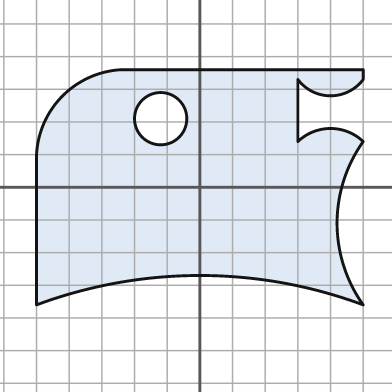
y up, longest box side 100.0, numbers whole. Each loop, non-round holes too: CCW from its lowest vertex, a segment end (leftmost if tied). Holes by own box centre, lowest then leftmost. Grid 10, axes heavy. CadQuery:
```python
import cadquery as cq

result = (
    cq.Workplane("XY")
    .moveTo(-50.0, -36.0)
    .threePointArc((0.0, -27.0), (50.0, -36.0))
    .threePointArc((42.0, -11.0), (50.0, 14.0))
    .threePointArc((40.0, 18.0), (30.0, 14.0))
    .lineTo(30.0, 33.0)
    .threePointArc((40.0, 28.0), (50.0, 33.0))
    .lineTo(50.0, 36.0)
    .lineTo(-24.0, 36.0)
    .threePointArc((-42.0, 28.0), (-50.0, 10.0))
    .close()
    .moveTo(-12.0, 21.0)
    .circle(8.0)
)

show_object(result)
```